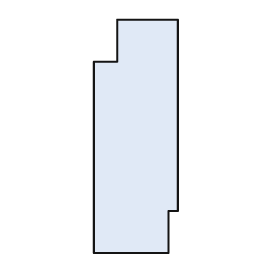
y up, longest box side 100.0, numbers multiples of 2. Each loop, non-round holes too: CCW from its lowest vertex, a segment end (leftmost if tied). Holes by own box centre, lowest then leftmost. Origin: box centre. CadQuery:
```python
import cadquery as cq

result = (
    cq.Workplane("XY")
    .moveTo(-18.0, -50.0)
    .lineTo(14.0, -50.0)
    .lineTo(14.0, -32.0)
    .lineTo(18.0, -32.0)
    .lineTo(18.0, 50.0)
    .lineTo(-8.0, 50.0)
    .lineTo(-8.0, 32.0)
    .lineTo(-18.0, 32.0)
    .close()
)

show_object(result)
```